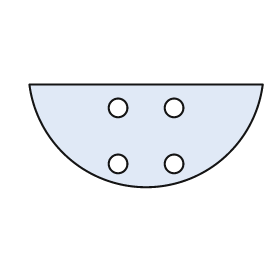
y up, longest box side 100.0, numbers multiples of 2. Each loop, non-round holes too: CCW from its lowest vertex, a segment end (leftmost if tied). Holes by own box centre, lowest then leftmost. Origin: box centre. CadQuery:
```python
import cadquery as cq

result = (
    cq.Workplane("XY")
    .moveTo(-50.0, 22.0)
    .threePointArc((0.0, -22.0), (50.0, 22.0))
    .close()
    .moveTo(-12.0, -12.0)
    .circle(4.0)
    .moveTo(12.0, -12.0)
    .circle(4.0)
    .moveTo(-12.0, 12.0)
    .circle(4.0)
    .moveTo(12.0, 12.0)
    .circle(4.0)
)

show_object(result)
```